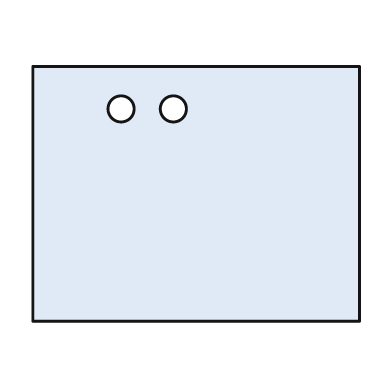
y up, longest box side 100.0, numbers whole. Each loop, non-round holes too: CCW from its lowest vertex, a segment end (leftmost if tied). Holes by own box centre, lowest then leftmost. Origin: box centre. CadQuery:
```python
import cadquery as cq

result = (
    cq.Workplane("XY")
    .moveTo(-50.0, -39.0)
    .lineTo(50.0, -39.0)
    .lineTo(50.0, 39.0)
    .lineTo(-50.0, 39.0)
    .close()
    .moveTo(-23.0, 26.0)
    .circle(4.0)
    .moveTo(-7.0, 26.0)
    .circle(4.0)
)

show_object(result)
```